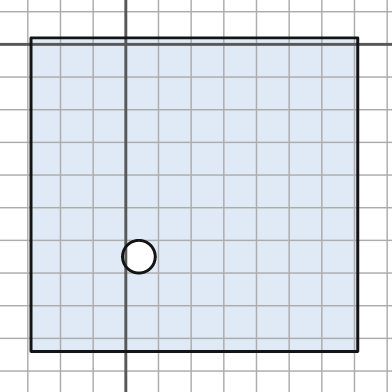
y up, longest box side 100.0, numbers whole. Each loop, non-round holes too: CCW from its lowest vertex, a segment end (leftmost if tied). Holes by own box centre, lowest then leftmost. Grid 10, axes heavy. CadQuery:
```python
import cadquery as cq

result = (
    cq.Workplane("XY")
    .moveTo(-29.0, -94.0)
    .lineTo(71.0, -94.0)
    .lineTo(71.0, 2.0)
    .lineTo(-29.0, 2.0)
    .close()
    .moveTo(4.0, -65.0)
    .circle(5.0)
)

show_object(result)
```